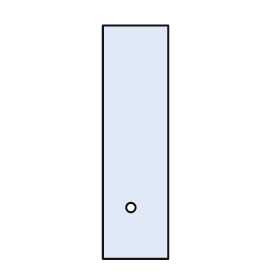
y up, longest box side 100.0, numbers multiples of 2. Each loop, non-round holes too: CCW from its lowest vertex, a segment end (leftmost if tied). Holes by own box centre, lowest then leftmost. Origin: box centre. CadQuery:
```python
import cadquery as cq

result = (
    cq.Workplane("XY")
    .moveTo(-14.0, -50.0)
    .lineTo(14.0, -50.0)
    .lineTo(14.0, 50.0)
    .lineTo(-14.0, 50.0)
    .close()
    .moveTo(-2.0, -28.0)
    .circle(2.0)
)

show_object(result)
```